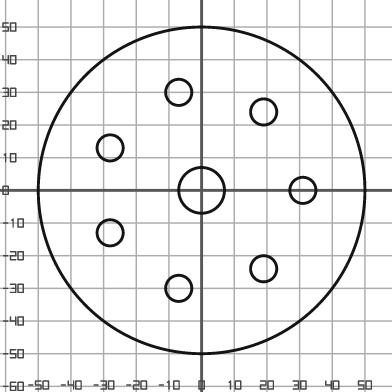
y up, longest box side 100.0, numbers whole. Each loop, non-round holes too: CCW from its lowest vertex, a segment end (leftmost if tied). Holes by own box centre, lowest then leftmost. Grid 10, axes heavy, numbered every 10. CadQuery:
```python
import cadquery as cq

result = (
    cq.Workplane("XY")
    .moveTo(0.0, 0.0)
    .circle(50.0)
    .moveTo(-7.0, -30.0)
    .circle(4.0)
    .moveTo(19.0, -24.0)
    .circle(4.0)
    .moveTo(-28.0, -13.0)
    .circle(4.0)
    .moveTo(0.0, 0.0)
    .circle(7.0)
    .moveTo(31.0, 0.0)
    .circle(4.0)
    .moveTo(-28.0, 13.0)
    .circle(4.0)
    .moveTo(19.0, 24.0)
    .circle(4.0)
    .moveTo(-7.0, 30.0)
    .circle(4.0)
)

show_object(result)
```